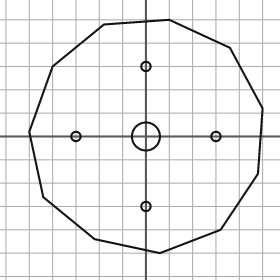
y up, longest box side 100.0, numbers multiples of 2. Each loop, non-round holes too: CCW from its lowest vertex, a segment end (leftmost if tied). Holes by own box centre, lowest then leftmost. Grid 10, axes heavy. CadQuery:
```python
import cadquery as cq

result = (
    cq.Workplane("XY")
    .moveTo(6.0, -50.0)
    .lineTo(32.0, -40.0)
    .lineTo(48.0, -16.0)
    .lineTo(50.0, 12.0)
    .lineTo(36.0, 38.0)
    .lineTo(10.0, 50.0)
    .lineTo(-18.0, 48.0)
    .lineTo(-40.0, 30.0)
    .lineTo(-50.0, 2.0)
    .lineTo(-44.0, -26.0)
    .lineTo(-22.0, -44.0)
    .close()
    .moveTo(0.0, -30.0)
    .circle(2.0)
    .moveTo(-30.0, 0.0)
    .circle(2.0)
    .moveTo(0.0, 0.0)
    .circle(6.0)
    .moveTo(30.0, 0.0)
    .circle(2.0)
    .moveTo(0.0, 30.0)
    .circle(2.0)
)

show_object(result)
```